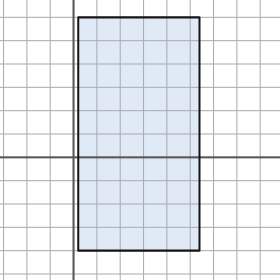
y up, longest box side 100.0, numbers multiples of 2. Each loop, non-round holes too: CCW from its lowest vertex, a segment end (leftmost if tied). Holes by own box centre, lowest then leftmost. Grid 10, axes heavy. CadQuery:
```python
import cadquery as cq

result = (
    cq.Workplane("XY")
    .moveTo(2.0, -40.0)
    .lineTo(54.0, -40.0)
    .lineTo(54.0, 60.0)
    .lineTo(2.0, 60.0)
    .close()
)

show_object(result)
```